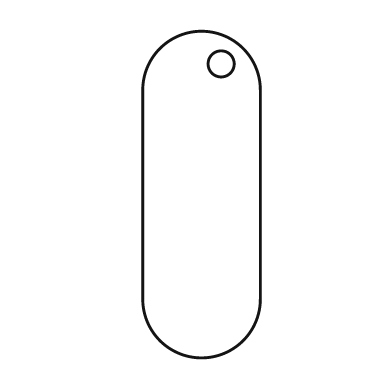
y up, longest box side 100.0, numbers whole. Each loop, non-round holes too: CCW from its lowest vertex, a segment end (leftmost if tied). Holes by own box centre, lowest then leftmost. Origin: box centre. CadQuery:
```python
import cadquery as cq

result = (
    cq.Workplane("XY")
    .moveTo(-18.0, -32.0)
    .threePointArc((0.0, -50.0), (18.0, -32.0))
    .lineTo(18.0, 32.0)
    .threePointArc((0.0, 50.0), (-18.0, 32.0))
    .close()
    .moveTo(6.0, 40.0)
    .circle(4.0)
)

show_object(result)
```